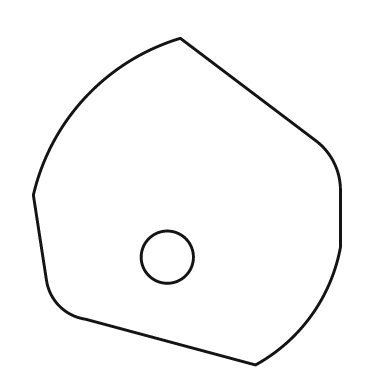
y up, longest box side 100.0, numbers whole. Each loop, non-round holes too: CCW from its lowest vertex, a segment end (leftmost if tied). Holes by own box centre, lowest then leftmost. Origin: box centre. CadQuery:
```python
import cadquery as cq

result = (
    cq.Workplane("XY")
    .moveTo(21.0, -50.0)
    .threePointArc((38.0, -35.0), (47.0, -14.0))
    .lineTo(47.0, 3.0)
    .threePointArc((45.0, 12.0), (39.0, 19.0))
    .lineTo(-2.0, 50.0)
    .threePointArc((-31.0, 32.0), (-47.0, 2.0))
    .lineTo(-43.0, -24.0)
    .threePointArc((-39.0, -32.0), (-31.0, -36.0))
    .close()
    .moveTo(-6.0, -17.0)
    .circle(8.0)
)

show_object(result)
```